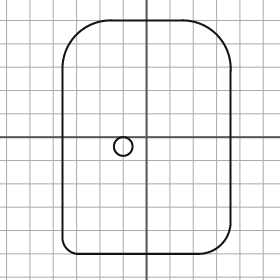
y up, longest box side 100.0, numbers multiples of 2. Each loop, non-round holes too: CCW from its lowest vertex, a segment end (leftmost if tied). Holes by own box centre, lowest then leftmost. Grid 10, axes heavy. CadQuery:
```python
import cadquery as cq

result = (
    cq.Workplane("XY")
    .moveTo(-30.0, -50.0)
    .lineTo(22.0, -50.0)
    .threePointArc((32.0, -46.0), (36.0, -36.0))
    .lineTo(36.0, 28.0)
    .threePointArc((30.0, 44.0), (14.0, 50.0))
    .lineTo(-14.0, 50.0)
    .threePointArc((-30.0, 44.0), (-36.0, 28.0))
    .lineTo(-36.0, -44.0)
    .threePointArc((-34.0, -48.0), (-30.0, -50.0))
    .close()
    .moveTo(-10.0, -4.0)
    .circle(4.0)
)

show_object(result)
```